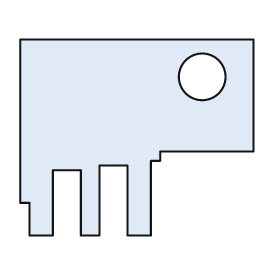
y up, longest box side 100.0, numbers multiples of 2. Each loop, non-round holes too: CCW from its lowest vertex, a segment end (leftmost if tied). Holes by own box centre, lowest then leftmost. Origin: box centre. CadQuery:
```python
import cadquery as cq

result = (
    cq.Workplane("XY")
    .moveTo(-46.0, -42.0)
    .lineTo(-36.0, -42.0)
    .lineTo(-36.0, -14.0)
    .lineTo(-24.0, -14.0)
    .lineTo(-24.0, -42.0)
    .lineTo(-16.0, -42.0)
    .lineTo(-16.0, -12.0)
    .lineTo(-4.0, -12.0)
    .lineTo(-4.0, -42.0)
    .lineTo(6.0, -42.0)
    .lineTo(6.0, -10.0)
    .lineTo(10.0, -10.0)
    .lineTo(10.0, -6.0)
    .lineTo(50.0, -6.0)
    .lineTo(50.0, 42.0)
    .lineTo(-50.0, 42.0)
    .lineTo(-50.0, -28.0)
    .lineTo(-46.0, -28.0)
    .close()
    .moveTo(28.0, 26.0)
    .circle(10.0)
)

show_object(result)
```